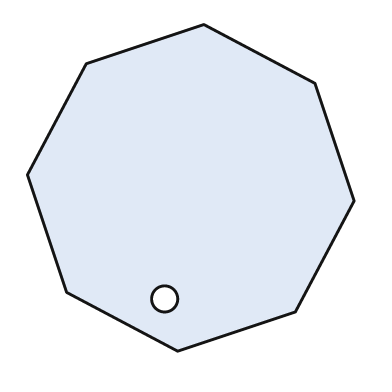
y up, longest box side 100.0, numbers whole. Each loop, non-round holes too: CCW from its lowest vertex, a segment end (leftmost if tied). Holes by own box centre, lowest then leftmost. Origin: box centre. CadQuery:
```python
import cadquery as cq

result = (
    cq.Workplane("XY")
    .moveTo(-4.0, -50.0)
    .lineTo(32.0, -38.0)
    .lineTo(50.0, -4.0)
    .lineTo(38.0, 32.0)
    .lineTo(4.0, 50.0)
    .lineTo(-32.0, 38.0)
    .lineTo(-50.0, 4.0)
    .lineTo(-38.0, -32.0)
    .close()
    .moveTo(-8.0, -34.0)
    .circle(4.0)
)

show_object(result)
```